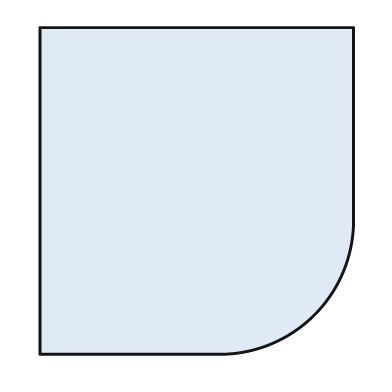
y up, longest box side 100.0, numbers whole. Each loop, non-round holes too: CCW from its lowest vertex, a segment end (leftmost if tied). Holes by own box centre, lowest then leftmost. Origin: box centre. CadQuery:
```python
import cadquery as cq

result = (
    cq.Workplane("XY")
    .moveTo(-48.0, -50.0)
    .lineTo(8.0, -50.0)
    .threePointArc((36.0, -38.0), (48.0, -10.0))
    .lineTo(48.0, 50.0)
    .lineTo(-48.0, 50.0)
    .close()
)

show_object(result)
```